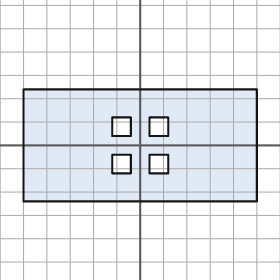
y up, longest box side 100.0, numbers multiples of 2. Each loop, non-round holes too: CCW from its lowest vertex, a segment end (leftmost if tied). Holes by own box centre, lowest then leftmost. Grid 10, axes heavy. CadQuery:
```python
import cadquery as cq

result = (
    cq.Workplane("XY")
    .moveTo(-50.0, -24.0)
    .lineTo(50.0, -24.0)
    .lineTo(50.0, 24.0)
    .lineTo(-50.0, 24.0)
    .close()
    .moveTo(-12.0, -12.0)
    .lineTo(-4.0, -12.0)
    .lineTo(-4.0, -4.0)
    .lineTo(-12.0, -4.0)
    .close()
    .moveTo(4.0, -12.0)
    .lineTo(12.0, -12.0)
    .lineTo(12.0, -4.0)
    .lineTo(4.0, -4.0)
    .close()
    .moveTo(-12.0, 4.0)
    .lineTo(-4.0, 4.0)
    .lineTo(-4.0, 12.0)
    .lineTo(-12.0, 12.0)
    .close()
    .moveTo(4.0, 4.0)
    .lineTo(12.0, 4.0)
    .lineTo(12.0, 12.0)
    .lineTo(4.0, 12.0)
    .close()
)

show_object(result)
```